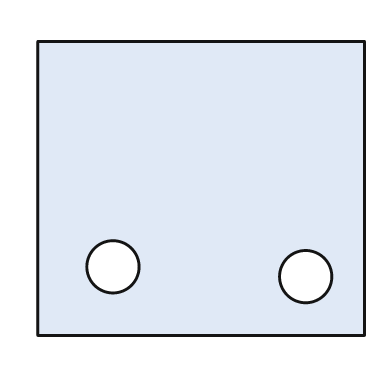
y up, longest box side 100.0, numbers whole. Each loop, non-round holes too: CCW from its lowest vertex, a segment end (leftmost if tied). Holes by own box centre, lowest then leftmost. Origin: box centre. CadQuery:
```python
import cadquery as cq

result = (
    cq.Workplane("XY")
    .moveTo(-50.0, -45.0)
    .lineTo(50.0, -45.0)
    .lineTo(50.0, 45.0)
    .lineTo(-50.0, 45.0)
    .close()
    .moveTo(32.0, -27.0)
    .circle(8.0)
    .moveTo(-27.0, -24.0)
    .circle(8.0)
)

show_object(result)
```